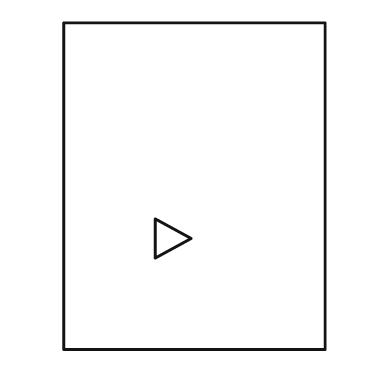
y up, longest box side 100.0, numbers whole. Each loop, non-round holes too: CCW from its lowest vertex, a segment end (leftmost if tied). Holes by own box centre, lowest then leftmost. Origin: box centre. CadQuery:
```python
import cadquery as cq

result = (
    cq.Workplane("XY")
    .moveTo(-40.0, -50.0)
    .lineTo(40.0, -50.0)
    .lineTo(40.0, 50.0)
    .lineTo(-40.0, 50.0)
    .close()
    .moveTo(-12.0, -22.0)
    .lineTo(-1.0, -16.0)
    .lineTo(-12.0, -10.0)
    .close()
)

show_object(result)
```